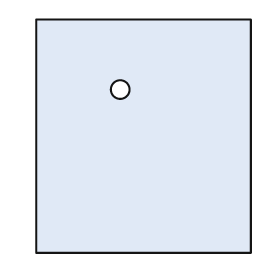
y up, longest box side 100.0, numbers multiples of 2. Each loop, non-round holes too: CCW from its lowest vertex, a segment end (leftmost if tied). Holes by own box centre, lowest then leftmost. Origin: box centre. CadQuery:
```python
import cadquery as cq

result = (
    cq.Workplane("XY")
    .moveTo(-46.0, -50.0)
    .lineTo(46.0, -50.0)
    .lineTo(46.0, 50.0)
    .lineTo(-46.0, 50.0)
    .close()
    .moveTo(-10.0, 20.0)
    .circle(4.0)
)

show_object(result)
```